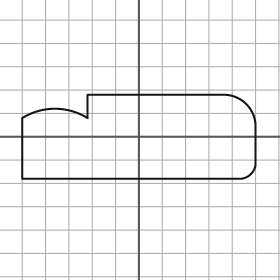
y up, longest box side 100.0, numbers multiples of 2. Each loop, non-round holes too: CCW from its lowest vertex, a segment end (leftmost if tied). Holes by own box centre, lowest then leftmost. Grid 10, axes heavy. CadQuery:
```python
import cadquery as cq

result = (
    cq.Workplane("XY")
    .moveTo(-50.0, -18.0)
    .lineTo(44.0, -18.0)
    .threePointArc((48.0, -16.0), (50.0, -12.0))
    .lineTo(50.0, 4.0)
    .threePointArc((46.0, 14.0), (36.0, 18.0))
    .lineTo(-22.0, 18.0)
    .lineTo(-22.0, 8.0)
    .threePointArc((-36.0, 12.0), (-50.0, 8.0))
    .close()
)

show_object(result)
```